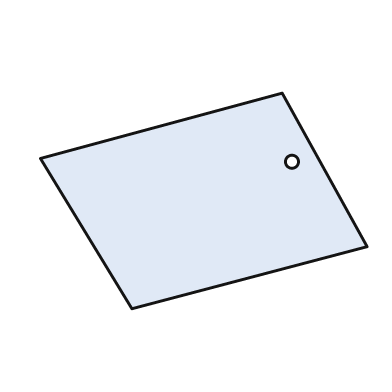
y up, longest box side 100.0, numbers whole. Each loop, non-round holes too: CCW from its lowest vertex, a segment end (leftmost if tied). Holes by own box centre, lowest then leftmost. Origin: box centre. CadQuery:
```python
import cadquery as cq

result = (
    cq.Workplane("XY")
    .moveTo(-22.0, -33.0)
    .lineTo(50.0, -14.0)
    .lineTo(24.0, 33.0)
    .lineTo(-50.0, 13.0)
    .close()
    .moveTo(27.0, 12.0)
    .circle(2.0)
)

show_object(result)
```